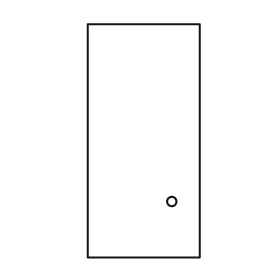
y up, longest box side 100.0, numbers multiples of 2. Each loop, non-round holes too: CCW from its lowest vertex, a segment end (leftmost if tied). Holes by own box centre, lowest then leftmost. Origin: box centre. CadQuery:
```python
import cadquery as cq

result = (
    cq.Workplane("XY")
    .moveTo(-24.0, -50.0)
    .lineTo(24.0, -50.0)
    .lineTo(24.0, 50.0)
    .lineTo(-24.0, 50.0)
    .close()
    .moveTo(12.0, -26.0)
    .circle(2.0)
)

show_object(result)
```